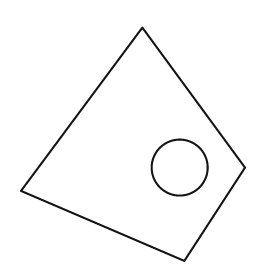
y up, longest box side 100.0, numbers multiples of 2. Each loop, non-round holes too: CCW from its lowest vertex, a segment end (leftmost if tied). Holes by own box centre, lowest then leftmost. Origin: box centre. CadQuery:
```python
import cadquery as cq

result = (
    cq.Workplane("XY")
    .moveTo(22.0, -50.0)
    .lineTo(48.0, -10.0)
    .lineTo(4.0, 50.0)
    .lineTo(-48.0, -20.0)
    .close()
    .moveTo(20.0, -10.0)
    .circle(12.0)
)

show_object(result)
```